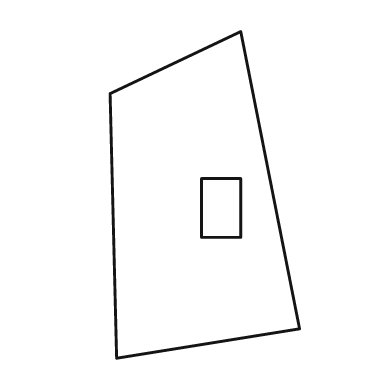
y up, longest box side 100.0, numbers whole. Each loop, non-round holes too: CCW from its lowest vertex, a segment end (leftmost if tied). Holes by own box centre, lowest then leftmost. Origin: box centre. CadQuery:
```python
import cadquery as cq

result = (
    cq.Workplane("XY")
    .moveTo(-27.0, -50.0)
    .lineTo(29.0, -41.0)
    .lineTo(11.0, 50.0)
    .lineTo(-29.0, 31.0)
    .close()
    .moveTo(-1.0, -13.0)
    .lineTo(11.0, -13.0)
    .lineTo(11.0, 5.0)
    .lineTo(-1.0, 5.0)
    .close()
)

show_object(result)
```